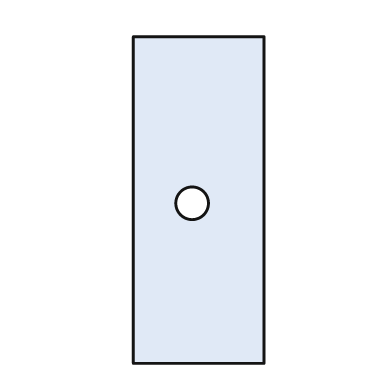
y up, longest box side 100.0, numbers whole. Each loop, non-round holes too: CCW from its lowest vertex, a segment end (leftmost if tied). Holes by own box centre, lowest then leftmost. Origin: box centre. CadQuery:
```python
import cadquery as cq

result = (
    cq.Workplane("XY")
    .moveTo(-20.0, -50.0)
    .lineTo(20.0, -50.0)
    .lineTo(20.0, 50.0)
    .lineTo(-20.0, 50.0)
    .close()
    .moveTo(-2.0, -1.0)
    .circle(5.0)
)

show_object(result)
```